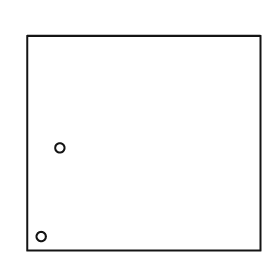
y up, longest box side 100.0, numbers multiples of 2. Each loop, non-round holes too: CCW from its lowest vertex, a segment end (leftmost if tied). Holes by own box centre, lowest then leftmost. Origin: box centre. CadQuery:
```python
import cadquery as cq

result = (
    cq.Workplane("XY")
    .moveTo(-50.0, -46.0)
    .lineTo(50.0, -46.0)
    .lineTo(50.0, 46.0)
    .lineTo(-50.0, 46.0)
    .close()
    .moveTo(-44.0, -40.0)
    .circle(2.0)
    .moveTo(-36.0, -2.0)
    .circle(2.0)
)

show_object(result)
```